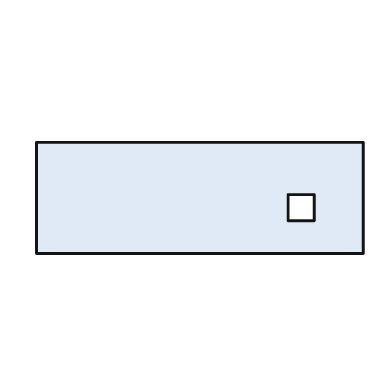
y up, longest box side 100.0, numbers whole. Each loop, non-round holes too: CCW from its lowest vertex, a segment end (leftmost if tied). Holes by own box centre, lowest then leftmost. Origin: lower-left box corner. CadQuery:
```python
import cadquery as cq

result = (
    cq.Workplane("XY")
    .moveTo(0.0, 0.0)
    .lineTo(100.0, 0.0)
    .lineTo(100.0, 34.0)
    .lineTo(0.0, 34.0)
    .close()
    .moveTo(77.0, 10.0)
    .lineTo(85.0, 10.0)
    .lineTo(85.0, 18.0)
    .lineTo(77.0, 18.0)
    .close()
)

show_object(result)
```